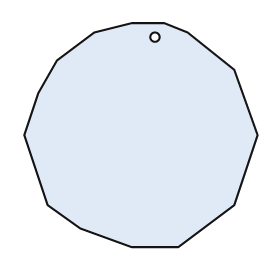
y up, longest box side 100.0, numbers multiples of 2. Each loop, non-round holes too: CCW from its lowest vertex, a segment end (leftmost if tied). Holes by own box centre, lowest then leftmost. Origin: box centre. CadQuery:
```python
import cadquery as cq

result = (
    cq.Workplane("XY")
    .moveTo(-4.0, -48.0)
    .lineTo(16.0, -48.0)
    .lineTo(40.0, -30.0)
    .lineTo(50.0, 0.0)
    .lineTo(40.0, 28.0)
    .lineTo(20.0, 44.0)
    .lineTo(10.0, 48.0)
    .lineTo(-4.0, 48.0)
    .lineTo(-20.0, 44.0)
    .lineTo(-36.0, 32.0)
    .lineTo(-44.0, 18.0)
    .lineTo(-50.0, 0.0)
    .lineTo(-40.0, -30.0)
    .lineTo(-26.0, -40.0)
    .close()
    .moveTo(6.0, 42.0)
    .circle(2.0)
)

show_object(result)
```